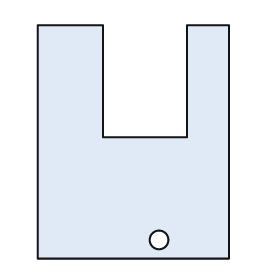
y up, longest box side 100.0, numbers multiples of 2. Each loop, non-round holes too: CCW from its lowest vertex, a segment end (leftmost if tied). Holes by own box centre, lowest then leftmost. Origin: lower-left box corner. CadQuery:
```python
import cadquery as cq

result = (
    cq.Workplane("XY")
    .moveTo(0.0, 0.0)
    .lineTo(82.0, 0.0)
    .lineTo(82.0, 100.0)
    .lineTo(64.0, 100.0)
    .lineTo(64.0, 52.0)
    .lineTo(28.0, 52.0)
    .lineTo(28.0, 100.0)
    .lineTo(0.0, 100.0)
    .close()
    .moveTo(52.0, 8.0)
    .circle(4.0)
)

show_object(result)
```